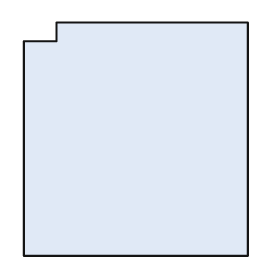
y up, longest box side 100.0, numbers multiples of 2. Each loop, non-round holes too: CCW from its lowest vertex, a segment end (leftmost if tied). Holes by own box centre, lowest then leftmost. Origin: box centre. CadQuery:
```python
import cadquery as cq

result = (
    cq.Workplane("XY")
    .moveTo(-48.0, -50.0)
    .lineTo(48.0, -50.0)
    .lineTo(48.0, 50.0)
    .lineTo(-34.0, 50.0)
    .lineTo(-34.0, 42.0)
    .lineTo(-48.0, 42.0)
    .close()
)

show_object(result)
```